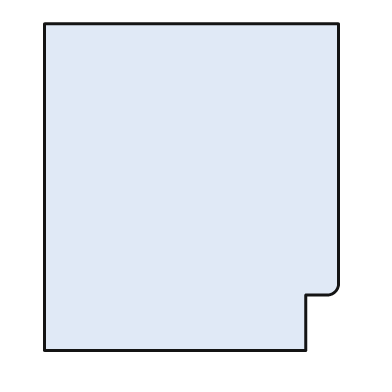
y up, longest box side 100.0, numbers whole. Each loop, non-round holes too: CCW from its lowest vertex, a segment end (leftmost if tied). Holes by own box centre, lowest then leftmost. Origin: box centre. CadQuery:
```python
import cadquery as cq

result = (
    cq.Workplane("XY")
    .moveTo(-45.0, -50.0)
    .lineTo(35.0, -50.0)
    .lineTo(35.0, -33.0)
    .lineTo(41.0, -33.0)
    .threePointArc((44.0, -32.0), (45.0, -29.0))
    .lineTo(45.0, 50.0)
    .lineTo(-45.0, 50.0)
    .close()
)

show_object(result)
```